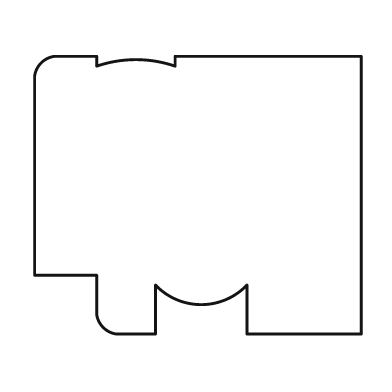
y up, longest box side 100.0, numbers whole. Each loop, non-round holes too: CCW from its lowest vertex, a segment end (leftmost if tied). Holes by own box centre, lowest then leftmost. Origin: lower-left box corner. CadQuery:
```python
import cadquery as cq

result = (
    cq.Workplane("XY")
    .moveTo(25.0, 0.0)
    .lineTo(37.0, 0.0)
    .lineTo(37.0, 15.0)
    .threePointArc((51.0, 9.0), (65.0, 15.0))
    .lineTo(65.0, 0.0)
    .lineTo(100.0, 0.0)
    .lineTo(100.0, 85.0)
    .lineTo(43.0, 85.0)
    .lineTo(43.0, 82.0)
    .threePointArc((31.0, 84.0), (19.0, 82.0))
    .lineTo(19.0, 85.0)
    .lineTo(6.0, 85.0)
    .threePointArc((2.0, 83.0), (0.0, 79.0))
    .lineTo(0.0, 18.0)
    .lineTo(19.0, 18.0)
    .lineTo(19.0, 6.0)
    .threePointArc((21.0, 2.0), (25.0, 0.0))
    .close()
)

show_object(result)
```